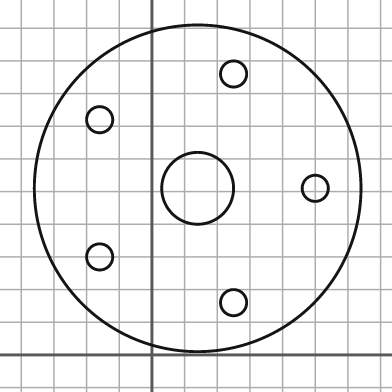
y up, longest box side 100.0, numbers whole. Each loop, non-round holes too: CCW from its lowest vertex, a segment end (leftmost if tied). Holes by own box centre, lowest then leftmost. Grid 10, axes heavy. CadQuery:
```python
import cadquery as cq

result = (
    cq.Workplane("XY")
    .moveTo(14.0, 51.0)
    .circle(50.0)
    .moveTo(25.0, 16.0)
    .circle(4.0)
    .moveTo(-16.0, 30.0)
    .circle(4.0)
    .moveTo(14.0, 51.0)
    .circle(11.0)
    .moveTo(50.0, 51.0)
    .circle(4.0)
    .moveTo(-16.0, 72.0)
    .circle(4.0)
    .moveTo(25.0, 86.0)
    .circle(4.0)
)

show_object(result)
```